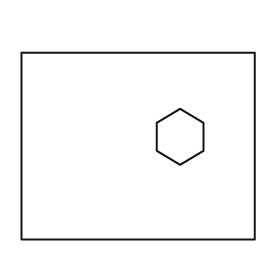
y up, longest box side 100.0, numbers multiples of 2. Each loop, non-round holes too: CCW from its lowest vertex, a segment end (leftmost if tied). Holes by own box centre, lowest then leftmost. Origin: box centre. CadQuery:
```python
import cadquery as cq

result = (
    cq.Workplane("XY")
    .moveTo(-50.0, -40.0)
    .lineTo(50.0, -40.0)
    .lineTo(50.0, 40.0)
    .lineTo(-50.0, 40.0)
    .close()
    .moveTo(18.0, -8.0)
    .lineTo(28.0, -2.0)
    .lineTo(28.0, 10.0)
    .lineTo(18.0, 16.0)
    .lineTo(8.0, 10.0)
    .lineTo(8.0, -2.0)
    .close()
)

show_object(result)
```